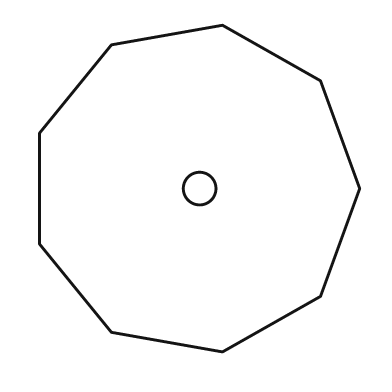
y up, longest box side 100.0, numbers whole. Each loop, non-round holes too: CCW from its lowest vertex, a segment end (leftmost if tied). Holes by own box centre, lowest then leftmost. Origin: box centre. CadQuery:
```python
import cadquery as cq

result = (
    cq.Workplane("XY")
    .moveTo(7.0, -50.0)
    .lineTo(37.0, -33.0)
    .lineTo(49.0, 0.0)
    .lineTo(37.0, 33.0)
    .lineTo(7.0, 50.0)
    .lineTo(-27.0, 44.0)
    .lineTo(-49.0, 17.0)
    .lineTo(-49.0, -17.0)
    .lineTo(-27.0, -44.0)
    .close()
    .moveTo(0.0, 0.0)
    .circle(5.0)
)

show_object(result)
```